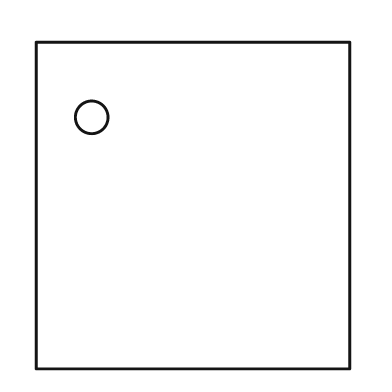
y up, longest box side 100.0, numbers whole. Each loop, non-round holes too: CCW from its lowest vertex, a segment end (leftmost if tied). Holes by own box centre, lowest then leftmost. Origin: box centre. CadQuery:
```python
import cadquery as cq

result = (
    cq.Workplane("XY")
    .moveTo(-48.0, -50.0)
    .lineTo(48.0, -50.0)
    .lineTo(48.0, 50.0)
    .lineTo(-48.0, 50.0)
    .close()
    .moveTo(-31.0, 27.0)
    .circle(5.0)
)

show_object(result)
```